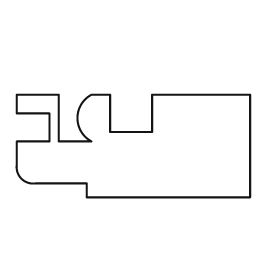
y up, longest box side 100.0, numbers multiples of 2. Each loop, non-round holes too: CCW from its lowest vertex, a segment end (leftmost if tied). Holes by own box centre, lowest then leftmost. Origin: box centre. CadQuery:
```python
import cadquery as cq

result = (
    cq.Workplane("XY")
    .moveTo(-20.0, -22.0)
    .lineTo(50.0, -22.0)
    .lineTo(50.0, 22.0)
    .lineTo(8.0, 22.0)
    .lineTo(8.0, 6.0)
    .lineTo(-10.0, 6.0)
    .lineTo(-10.0, 22.0)
    .lineTo(-18.0, 22.0)
    .threePointArc((-24.0, 12.0), (-18.0, 2.0))
    .lineTo(-32.0, 2.0)
    .lineTo(-32.0, 22.0)
    .lineTo(-50.0, 22.0)
    .lineTo(-50.0, 14.0)
    .lineTo(-36.0, 14.0)
    .lineTo(-36.0, 2.0)
    .lineTo(-50.0, 2.0)
    .lineTo(-50.0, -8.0)
    .threePointArc((-48.0, -14.0), (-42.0, -16.0))
    .lineTo(-20.0, -16.0)
    .close()
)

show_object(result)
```